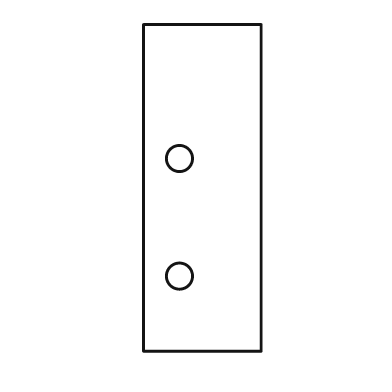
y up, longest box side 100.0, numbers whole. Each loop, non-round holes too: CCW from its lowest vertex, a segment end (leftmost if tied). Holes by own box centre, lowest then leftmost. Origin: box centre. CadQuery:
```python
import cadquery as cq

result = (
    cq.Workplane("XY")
    .moveTo(-18.0, -50.0)
    .lineTo(18.0, -50.0)
    .lineTo(18.0, 50.0)
    .lineTo(-18.0, 50.0)
    .close()
    .moveTo(-7.0, -27.0)
    .circle(4.0)
    .moveTo(-7.0, 9.0)
    .circle(4.0)
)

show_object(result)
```